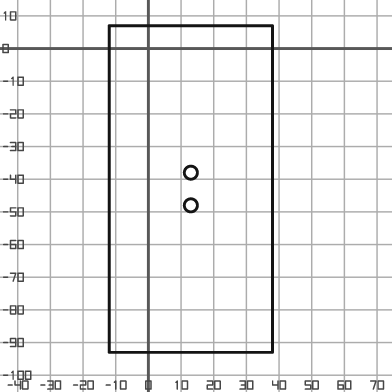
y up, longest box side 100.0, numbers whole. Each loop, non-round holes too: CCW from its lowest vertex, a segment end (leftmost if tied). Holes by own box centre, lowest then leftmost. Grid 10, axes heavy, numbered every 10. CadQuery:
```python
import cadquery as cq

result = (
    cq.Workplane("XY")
    .moveTo(-12.0, -93.0)
    .lineTo(38.0, -93.0)
    .lineTo(38.0, 7.0)
    .lineTo(-12.0, 7.0)
    .close()
    .moveTo(13.0, -48.0)
    .circle(2.0)
    .moveTo(13.0, -38.0)
    .circle(2.0)
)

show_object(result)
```